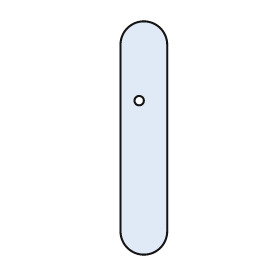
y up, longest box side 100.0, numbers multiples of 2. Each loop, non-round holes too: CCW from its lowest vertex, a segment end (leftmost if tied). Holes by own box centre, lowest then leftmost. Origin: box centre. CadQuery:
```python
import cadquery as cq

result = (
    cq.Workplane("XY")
    .moveTo(-10.0, -40.0)
    .threePointArc((0.0, -50.0), (10.0, -40.0))
    .lineTo(10.0, 40.0)
    .threePointArc((0.0, 50.0), (-10.0, 40.0))
    .close()
    .moveTo(-2.0, 16.0)
    .circle(2.0)
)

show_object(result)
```